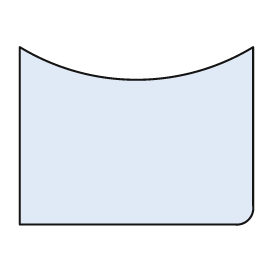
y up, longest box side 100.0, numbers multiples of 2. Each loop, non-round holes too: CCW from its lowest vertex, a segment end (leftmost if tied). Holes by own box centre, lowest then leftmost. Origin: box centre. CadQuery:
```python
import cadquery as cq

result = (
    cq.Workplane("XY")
    .moveTo(-50.0, -38.0)
    .lineTo(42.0, -38.0)
    .threePointArc((48.0, -36.0), (50.0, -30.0))
    .lineTo(50.0, 38.0)
    .threePointArc((0.0, 24.0), (-50.0, 38.0))
    .close()
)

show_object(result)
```